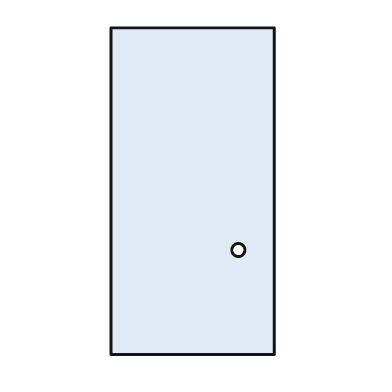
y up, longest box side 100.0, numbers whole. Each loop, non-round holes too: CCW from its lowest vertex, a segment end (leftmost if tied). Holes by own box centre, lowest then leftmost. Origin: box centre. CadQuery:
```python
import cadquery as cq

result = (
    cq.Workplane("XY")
    .moveTo(-25.0, -50.0)
    .lineTo(25.0, -50.0)
    .lineTo(25.0, 50.0)
    .lineTo(-25.0, 50.0)
    .close()
    .moveTo(14.0, -18.0)
    .circle(2.0)
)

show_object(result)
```